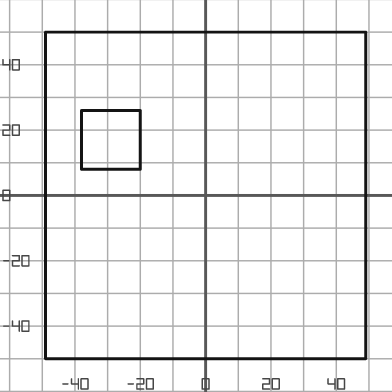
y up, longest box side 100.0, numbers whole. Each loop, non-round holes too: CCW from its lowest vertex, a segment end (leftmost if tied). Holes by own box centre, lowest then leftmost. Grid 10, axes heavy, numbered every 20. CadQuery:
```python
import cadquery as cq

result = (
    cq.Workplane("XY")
    .moveTo(-49.0, -50.0)
    .lineTo(49.0, -50.0)
    .lineTo(49.0, 50.0)
    .lineTo(-49.0, 50.0)
    .close()
    .moveTo(-38.0, 8.0)
    .lineTo(-20.0, 8.0)
    .lineTo(-20.0, 26.0)
    .lineTo(-38.0, 26.0)
    .close()
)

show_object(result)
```